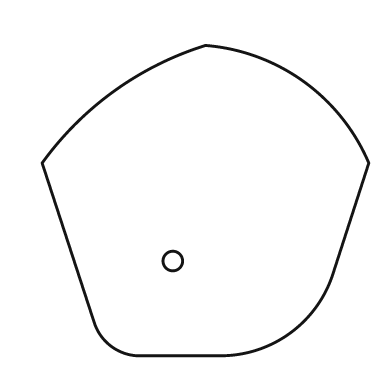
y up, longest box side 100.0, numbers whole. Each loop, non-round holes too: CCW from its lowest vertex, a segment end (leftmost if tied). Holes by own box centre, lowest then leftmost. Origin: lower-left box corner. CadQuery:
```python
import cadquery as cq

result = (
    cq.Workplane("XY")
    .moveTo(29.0, 0.0)
    .lineTo(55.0, 0.0)
    .threePointArc((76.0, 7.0), (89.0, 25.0))
    .lineTo(100.0, 59.0)
    .threePointArc((80.0, 84.0), (50.0, 95.0))
    .threePointArc((22.0, 81.0), (0.0, 59.0))
    .lineTo(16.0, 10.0)
    .threePointArc((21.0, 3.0), (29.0, 0.0))
    .close()
    .moveTo(40.0, 29.0)
    .circle(3.0)
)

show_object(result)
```